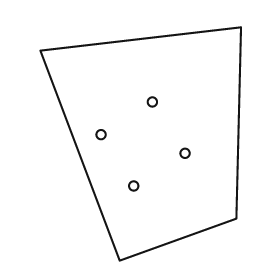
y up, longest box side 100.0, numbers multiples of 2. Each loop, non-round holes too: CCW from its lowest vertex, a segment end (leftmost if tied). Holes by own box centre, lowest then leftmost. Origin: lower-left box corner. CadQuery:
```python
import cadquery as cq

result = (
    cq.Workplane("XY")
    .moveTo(34.0, 0.0)
    .lineTo(84.0, 18.0)
    .lineTo(86.0, 100.0)
    .lineTo(0.0, 90.0)
    .close()
    .moveTo(40.0, 32.0)
    .circle(2.0)
    .moveTo(62.0, 46.0)
    .circle(2.0)
    .moveTo(26.0, 54.0)
    .circle(2.0)
    .moveTo(48.0, 68.0)
    .circle(2.0)
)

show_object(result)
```